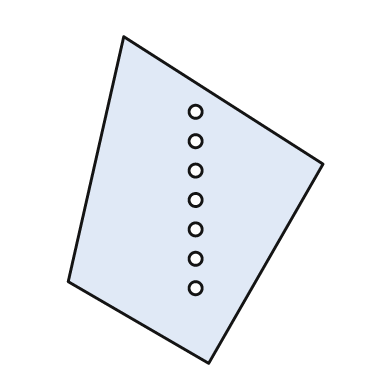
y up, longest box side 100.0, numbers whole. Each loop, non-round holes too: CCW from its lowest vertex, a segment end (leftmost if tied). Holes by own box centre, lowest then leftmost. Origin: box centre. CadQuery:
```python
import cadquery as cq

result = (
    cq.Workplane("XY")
    .moveTo(4.0, -50.0)
    .lineTo(39.0, 11.0)
    .lineTo(-22.0, 50.0)
    .lineTo(-39.0, -25.0)
    .close()
    .moveTo(0.0, -27.0)
    .circle(2.0)
    .moveTo(0.0, -18.0)
    .circle(2.0)
    .moveTo(0.0, -9.0)
    .circle(2.0)
    .moveTo(0.0, 0.0)
    .circle(2.0)
    .moveTo(0.0, 9.0)
    .circle(2.0)
    .moveTo(0.0, 18.0)
    .circle(2.0)
    .moveTo(0.0, 27.0)
    .circle(2.0)
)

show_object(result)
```